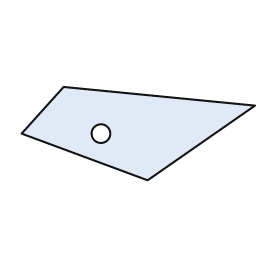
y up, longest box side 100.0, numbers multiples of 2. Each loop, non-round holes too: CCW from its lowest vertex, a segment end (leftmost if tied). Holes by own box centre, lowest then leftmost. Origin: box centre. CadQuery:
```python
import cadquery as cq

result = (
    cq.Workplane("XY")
    .moveTo(4.0, -20.0)
    .lineTo(50.0, 12.0)
    .lineTo(-32.0, 20.0)
    .lineTo(-50.0, 0.0)
    .close()
    .moveTo(-16.0, 0.0)
    .circle(4.0)
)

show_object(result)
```